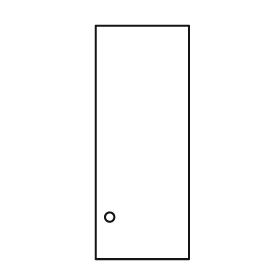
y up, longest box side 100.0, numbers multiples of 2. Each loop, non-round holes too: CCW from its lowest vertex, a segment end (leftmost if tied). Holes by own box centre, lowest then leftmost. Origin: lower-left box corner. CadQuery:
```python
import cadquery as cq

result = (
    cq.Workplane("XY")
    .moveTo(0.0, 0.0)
    .lineTo(40.0, 0.0)
    .lineTo(40.0, 100.0)
    .lineTo(0.0, 100.0)
    .close()
    .moveTo(6.0, 18.0)
    .circle(2.0)
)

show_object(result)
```